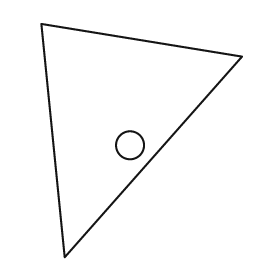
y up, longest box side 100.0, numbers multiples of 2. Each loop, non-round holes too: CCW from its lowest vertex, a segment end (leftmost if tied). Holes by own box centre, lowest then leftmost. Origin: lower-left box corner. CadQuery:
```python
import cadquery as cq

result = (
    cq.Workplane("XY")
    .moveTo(10.0, 0.0)
    .lineTo(86.0, 86.0)
    .lineTo(0.0, 100.0)
    .close()
    .moveTo(38.0, 48.0)
    .circle(6.0)
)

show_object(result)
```